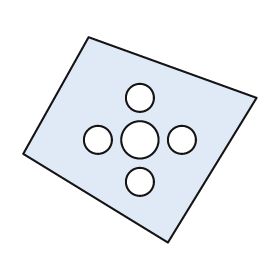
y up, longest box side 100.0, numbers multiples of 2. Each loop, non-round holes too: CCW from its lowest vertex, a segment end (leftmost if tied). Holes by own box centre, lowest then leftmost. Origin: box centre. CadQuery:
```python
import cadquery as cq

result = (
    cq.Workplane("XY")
    .moveTo(12.0, -44.0)
    .lineTo(50.0, 18.0)
    .lineTo(-22.0, 44.0)
    .lineTo(-50.0, -6.0)
    .close()
    .moveTo(0.0, -18.0)
    .circle(6.0)
    .moveTo(-18.0, 0.0)
    .circle(6.0)
    .moveTo(0.0, 0.0)
    .circle(8.0)
    .moveTo(18.0, 0.0)
    .circle(6.0)
    .moveTo(0.0, 18.0)
    .circle(6.0)
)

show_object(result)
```